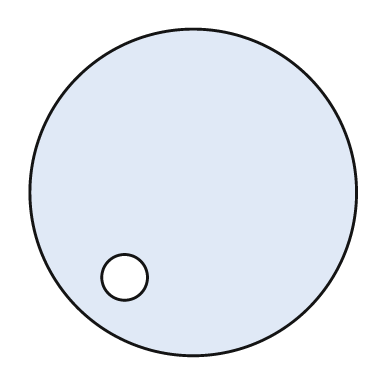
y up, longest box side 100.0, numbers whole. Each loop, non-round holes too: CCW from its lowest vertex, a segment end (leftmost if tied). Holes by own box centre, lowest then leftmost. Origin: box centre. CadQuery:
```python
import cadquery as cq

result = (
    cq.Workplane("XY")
    .moveTo(0.0, 0.0)
    .circle(50.0)
    .moveTo(-21.0, -26.0)
    .circle(7.0)
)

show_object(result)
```